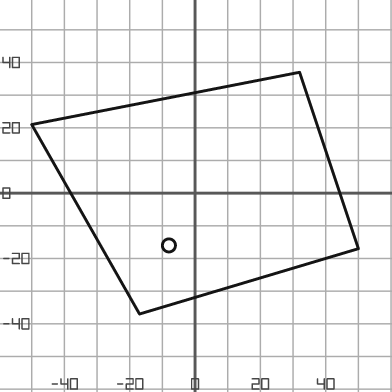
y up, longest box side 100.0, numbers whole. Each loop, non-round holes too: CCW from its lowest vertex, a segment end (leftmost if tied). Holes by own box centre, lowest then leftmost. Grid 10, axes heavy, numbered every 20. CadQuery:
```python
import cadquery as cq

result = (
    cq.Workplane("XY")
    .moveTo(-17.0, -37.0)
    .lineTo(50.0, -17.0)
    .lineTo(32.0, 37.0)
    .lineTo(-50.0, 21.0)
    .close()
    .moveTo(-8.0, -16.0)
    .circle(2.0)
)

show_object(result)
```